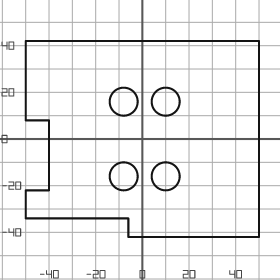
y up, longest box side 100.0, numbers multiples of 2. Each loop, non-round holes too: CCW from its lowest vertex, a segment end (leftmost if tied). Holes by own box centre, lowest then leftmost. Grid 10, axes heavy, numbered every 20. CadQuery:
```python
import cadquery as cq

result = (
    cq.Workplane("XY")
    .moveTo(-6.0, -42.0)
    .lineTo(50.0, -42.0)
    .lineTo(50.0, 42.0)
    .lineTo(-50.0, 42.0)
    .lineTo(-50.0, 8.0)
    .lineTo(-40.0, 8.0)
    .lineTo(-40.0, -22.0)
    .lineTo(-50.0, -22.0)
    .lineTo(-50.0, -34.0)
    .lineTo(-6.0, -34.0)
    .close()
    .moveTo(-8.0, -16.0)
    .circle(6.0)
    .moveTo(10.0, -16.0)
    .circle(6.0)
    .moveTo(-8.0, 16.0)
    .circle(6.0)
    .moveTo(10.0, 16.0)
    .circle(6.0)
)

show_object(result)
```